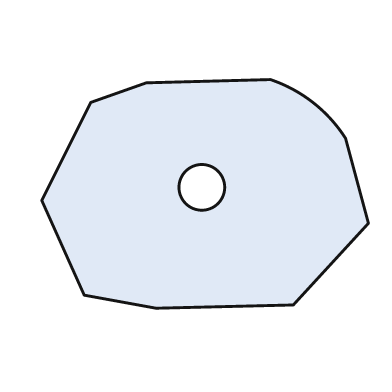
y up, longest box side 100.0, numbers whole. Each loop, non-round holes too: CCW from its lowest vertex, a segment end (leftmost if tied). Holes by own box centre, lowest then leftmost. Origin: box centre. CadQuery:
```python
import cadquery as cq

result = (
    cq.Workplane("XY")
    .moveTo(-15.0, -35.0)
    .lineTo(27.0, -34.0)
    .lineTo(50.0, -9.0)
    .lineTo(43.0, 17.0)
    .threePointArc((33.0, 28.0), (20.0, 35.0))
    .lineTo(-18.0, 34.0)
    .lineTo(-35.0, 28.0)
    .lineTo(-50.0, -2.0)
    .lineTo(-37.0, -31.0)
    .close()
    .moveTo(-1.0, 2.0)
    .circle(7.0)
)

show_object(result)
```